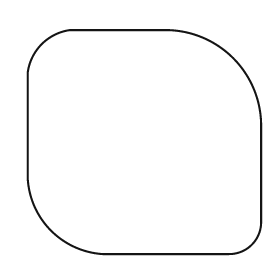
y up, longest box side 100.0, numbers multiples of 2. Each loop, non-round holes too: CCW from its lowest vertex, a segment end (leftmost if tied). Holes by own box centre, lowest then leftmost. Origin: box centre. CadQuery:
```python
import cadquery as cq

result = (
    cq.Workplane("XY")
    .moveTo(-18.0, -48.0)
    .lineTo(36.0, -48.0)
    .threePointArc((46.0, -44.0), (50.0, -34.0))
    .lineTo(50.0, 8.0)
    .threePointArc((38.0, 36.0), (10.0, 48.0))
    .lineTo(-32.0, 48.0)
    .threePointArc((-44.0, 42.0), (-50.0, 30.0))
    .lineTo(-50.0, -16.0)
    .threePointArc((-40.0, -38.0), (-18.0, -48.0))
    .close()
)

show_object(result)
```